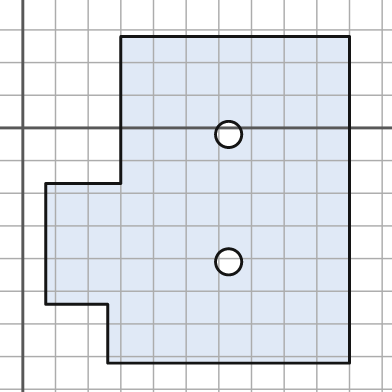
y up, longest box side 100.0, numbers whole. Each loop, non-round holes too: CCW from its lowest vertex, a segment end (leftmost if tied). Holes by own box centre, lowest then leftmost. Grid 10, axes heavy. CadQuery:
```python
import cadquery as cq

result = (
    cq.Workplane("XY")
    .moveTo(26.0, -72.0)
    .lineTo(100.0, -72.0)
    .lineTo(100.0, 28.0)
    .lineTo(30.0, 28.0)
    .lineTo(30.0, -17.0)
    .lineTo(7.0, -17.0)
    .lineTo(7.0, -54.0)
    .lineTo(26.0, -54.0)
    .close()
    .moveTo(63.0, -41.0)
    .circle(4.0)
    .moveTo(63.0, -2.0)
    .circle(4.0)
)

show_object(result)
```